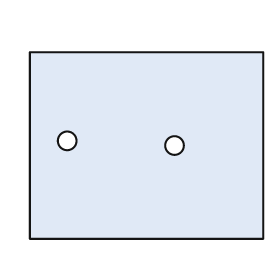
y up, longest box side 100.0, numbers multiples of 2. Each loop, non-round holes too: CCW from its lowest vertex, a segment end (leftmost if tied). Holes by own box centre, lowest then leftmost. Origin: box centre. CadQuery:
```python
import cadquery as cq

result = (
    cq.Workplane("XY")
    .moveTo(-50.0, -40.0)
    .lineTo(50.0, -40.0)
    .lineTo(50.0, 40.0)
    .lineTo(-50.0, 40.0)
    .close()
    .moveTo(12.0, 0.0)
    .circle(4.0)
    .moveTo(-34.0, 2.0)
    .circle(4.0)
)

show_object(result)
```